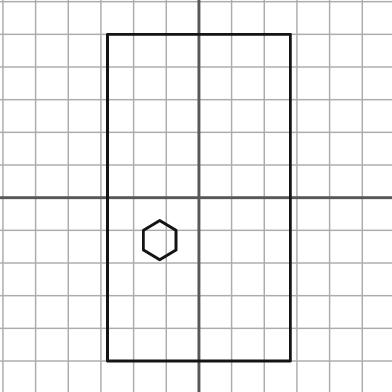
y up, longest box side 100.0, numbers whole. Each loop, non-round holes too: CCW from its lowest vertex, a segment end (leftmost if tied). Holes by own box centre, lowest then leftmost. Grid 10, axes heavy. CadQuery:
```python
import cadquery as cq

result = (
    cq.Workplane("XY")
    .moveTo(-28.0, -50.0)
    .lineTo(28.0, -50.0)
    .lineTo(28.0, 50.0)
    .lineTo(-28.0, 50.0)
    .close()
    .moveTo(-12.0, -19.0)
    .lineTo(-7.0, -16.0)
    .lineTo(-7.0, -10.0)
    .lineTo(-12.0, -7.0)
    .lineTo(-17.0, -10.0)
    .lineTo(-17.0, -16.0)
    .close()
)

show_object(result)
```